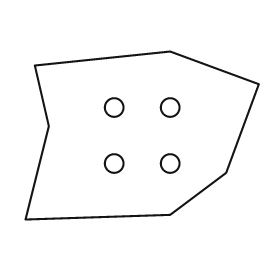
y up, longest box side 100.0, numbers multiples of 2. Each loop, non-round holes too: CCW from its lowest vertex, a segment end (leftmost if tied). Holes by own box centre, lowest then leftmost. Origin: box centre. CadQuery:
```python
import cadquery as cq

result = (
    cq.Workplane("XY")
    .moveTo(-50.0, -36.0)
    .lineTo(12.0, -34.0)
    .lineTo(36.0, -16.0)
    .lineTo(50.0, 22.0)
    .lineTo(12.0, 36.0)
    .lineTo(-46.0, 30.0)
    .lineTo(-40.0, 4.0)
    .close()
    .moveTo(-12.0, -12.0)
    .circle(4.0)
    .moveTo(12.0, -12.0)
    .circle(4.0)
    .moveTo(-12.0, 12.0)
    .circle(4.0)
    .moveTo(12.0, 12.0)
    .circle(4.0)
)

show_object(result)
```